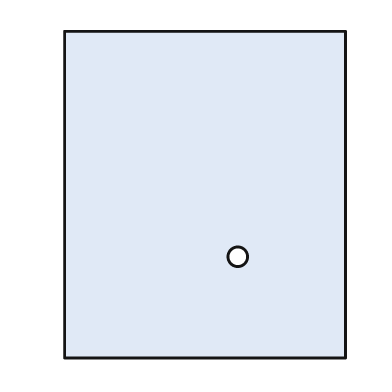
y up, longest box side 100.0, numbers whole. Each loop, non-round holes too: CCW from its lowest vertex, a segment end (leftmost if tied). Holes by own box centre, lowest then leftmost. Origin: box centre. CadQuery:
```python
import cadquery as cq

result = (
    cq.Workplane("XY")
    .moveTo(-43.0, -50.0)
    .lineTo(43.0, -50.0)
    .lineTo(43.0, 50.0)
    .lineTo(-43.0, 50.0)
    .close()
    .moveTo(10.0, -19.0)
    .circle(3.0)
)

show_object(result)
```